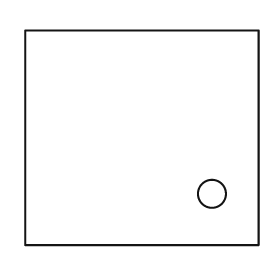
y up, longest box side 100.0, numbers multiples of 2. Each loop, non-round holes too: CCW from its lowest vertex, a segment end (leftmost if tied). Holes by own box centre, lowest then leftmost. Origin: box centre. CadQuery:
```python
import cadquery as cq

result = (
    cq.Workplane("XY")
    .moveTo(-50.0, -46.0)
    .lineTo(50.0, -46.0)
    .lineTo(50.0, 46.0)
    .lineTo(-50.0, 46.0)
    .close()
    .moveTo(30.0, -24.0)
    .circle(6.0)
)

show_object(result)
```